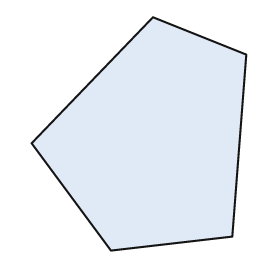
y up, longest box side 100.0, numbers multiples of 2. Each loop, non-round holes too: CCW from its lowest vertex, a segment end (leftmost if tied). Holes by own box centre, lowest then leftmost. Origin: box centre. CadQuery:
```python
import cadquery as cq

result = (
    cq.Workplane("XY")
    .moveTo(-12.0, -50.0)
    .lineTo(40.0, -44.0)
    .lineTo(46.0, 34.0)
    .lineTo(6.0, 50.0)
    .lineTo(-46.0, -4.0)
    .close()
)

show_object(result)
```